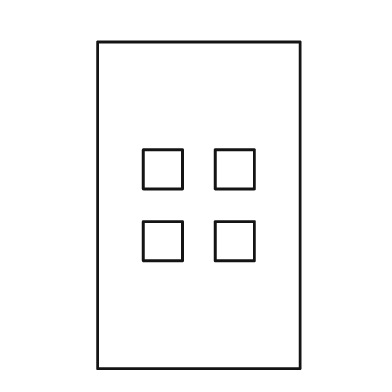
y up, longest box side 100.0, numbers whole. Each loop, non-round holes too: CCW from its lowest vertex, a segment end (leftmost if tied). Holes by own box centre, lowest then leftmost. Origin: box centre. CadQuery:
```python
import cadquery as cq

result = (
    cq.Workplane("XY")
    .moveTo(-31.0, -50.0)
    .lineTo(31.0, -50.0)
    .lineTo(31.0, 50.0)
    .lineTo(-31.0, 50.0)
    .close()
    .moveTo(-17.0, -17.0)
    .lineTo(-5.0, -17.0)
    .lineTo(-5.0, -5.0)
    .lineTo(-17.0, -5.0)
    .close()
    .moveTo(5.0, -17.0)
    .lineTo(17.0, -17.0)
    .lineTo(17.0, -5.0)
    .lineTo(5.0, -5.0)
    .close()
    .moveTo(-17.0, 5.0)
    .lineTo(-5.0, 5.0)
    .lineTo(-5.0, 17.0)
    .lineTo(-17.0, 17.0)
    .close()
    .moveTo(5.0, 5.0)
    .lineTo(17.0, 5.0)
    .lineTo(17.0, 17.0)
    .lineTo(5.0, 17.0)
    .close()
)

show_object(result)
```